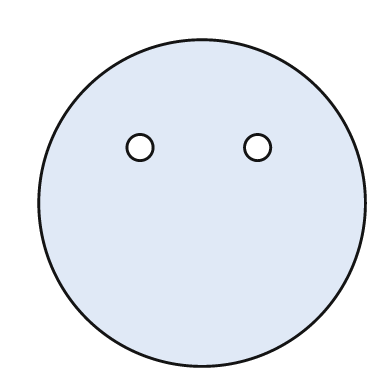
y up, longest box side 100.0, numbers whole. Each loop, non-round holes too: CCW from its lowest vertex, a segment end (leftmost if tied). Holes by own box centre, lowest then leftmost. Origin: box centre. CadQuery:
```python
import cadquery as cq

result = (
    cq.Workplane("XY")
    .moveTo(0.0, 0.0)
    .circle(50.0)
    .moveTo(-19.0, 17.0)
    .circle(4.0)
    .moveTo(17.0, 17.0)
    .circle(4.0)
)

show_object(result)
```